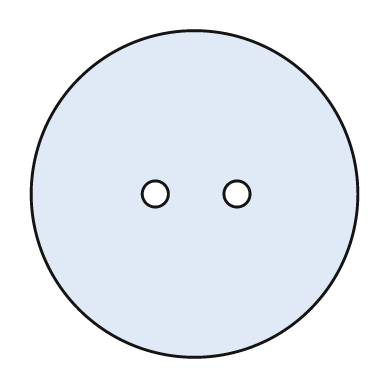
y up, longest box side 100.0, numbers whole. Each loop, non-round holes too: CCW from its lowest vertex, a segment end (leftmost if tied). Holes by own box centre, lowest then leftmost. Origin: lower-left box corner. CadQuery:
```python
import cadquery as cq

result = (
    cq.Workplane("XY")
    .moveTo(50.0, 50.0)
    .circle(50.0)
    .moveTo(38.0, 50.0)
    .circle(4.0)
    .moveTo(63.0, 50.0)
    .circle(4.0)
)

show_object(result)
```